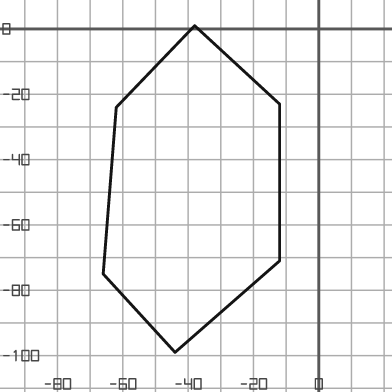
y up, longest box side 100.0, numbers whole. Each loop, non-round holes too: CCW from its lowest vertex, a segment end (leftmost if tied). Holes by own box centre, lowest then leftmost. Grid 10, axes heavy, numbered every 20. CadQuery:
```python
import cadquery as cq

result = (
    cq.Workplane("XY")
    .moveTo(-44.0, -99.0)
    .lineTo(-12.0, -71.0)
    .lineTo(-12.0, -23.0)
    .lineTo(-38.0, 1.0)
    .lineTo(-62.0, -24.0)
    .lineTo(-66.0, -75.0)
    .close()
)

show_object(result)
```